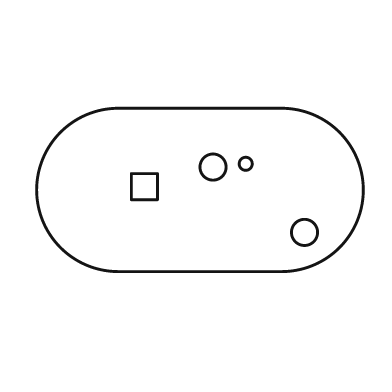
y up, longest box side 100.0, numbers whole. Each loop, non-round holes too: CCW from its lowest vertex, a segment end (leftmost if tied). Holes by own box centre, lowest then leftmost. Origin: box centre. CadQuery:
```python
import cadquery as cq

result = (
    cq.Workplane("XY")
    .moveTo(-25.0, -25.0)
    .lineTo(25.0, -25.0)
    .threePointArc((50.0, 0.0), (25.0, 25.0))
    .lineTo(-25.0, 25.0)
    .threePointArc((-50.0, 0.0), (-25.0, -25.0))
    .close()
    .moveTo(32.0, -13.0)
    .circle(4.0)
    .moveTo(-21.0, -3.0)
    .lineTo(-13.0, -3.0)
    .lineTo(-13.0, 5.0)
    .lineTo(-21.0, 5.0)
    .close()
    .moveTo(4.0, 7.0)
    .circle(4.0)
    .moveTo(14.0, 8.0)
    .circle(2.0)
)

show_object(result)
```